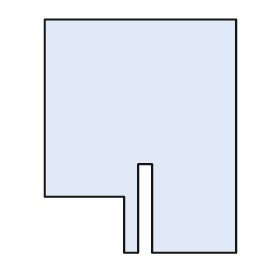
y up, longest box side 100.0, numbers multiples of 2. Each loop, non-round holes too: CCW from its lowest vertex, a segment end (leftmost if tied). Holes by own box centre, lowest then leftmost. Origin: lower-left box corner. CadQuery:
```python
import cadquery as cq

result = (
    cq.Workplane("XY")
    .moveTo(34.0, 0.0)
    .lineTo(40.0, 0.0)
    .lineTo(40.0, 38.0)
    .lineTo(46.0, 38.0)
    .lineTo(46.0, 0.0)
    .lineTo(82.0, 0.0)
    .lineTo(82.0, 100.0)
    .lineTo(0.0, 100.0)
    .lineTo(0.0, 24.0)
    .lineTo(34.0, 24.0)
    .close()
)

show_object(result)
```